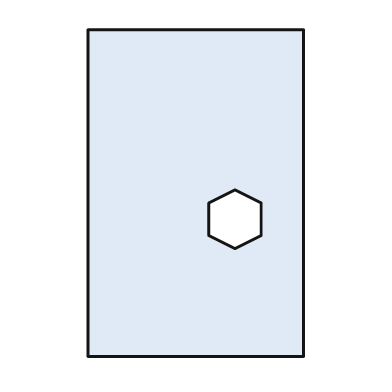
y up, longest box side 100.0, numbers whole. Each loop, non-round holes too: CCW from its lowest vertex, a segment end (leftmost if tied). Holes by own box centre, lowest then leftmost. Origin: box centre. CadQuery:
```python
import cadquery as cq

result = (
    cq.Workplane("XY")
    .moveTo(-33.0, -50.0)
    .lineTo(33.0, -50.0)
    .lineTo(33.0, 50.0)
    .lineTo(-33.0, 50.0)
    .close()
    .moveTo(12.0, -17.0)
    .lineTo(20.0, -13.0)
    .lineTo(20.0, -3.0)
    .lineTo(12.0, 1.0)
    .lineTo(4.0, -3.0)
    .lineTo(4.0, -13.0)
    .close()
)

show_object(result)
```